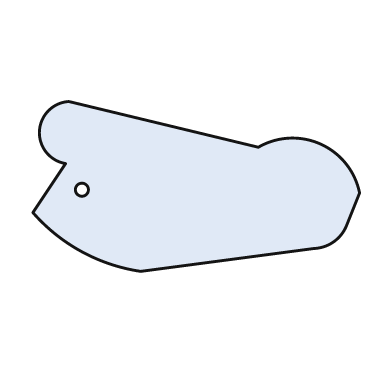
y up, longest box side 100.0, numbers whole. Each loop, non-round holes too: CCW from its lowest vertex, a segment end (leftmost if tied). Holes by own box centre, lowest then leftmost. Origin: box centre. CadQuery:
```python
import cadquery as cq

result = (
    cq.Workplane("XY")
    .moveTo(-17.0, -26.0)
    .lineTo(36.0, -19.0)
    .threePointArc((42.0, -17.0), (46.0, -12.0))
    .lineTo(50.0, -2.0)
    .threePointArc((38.0, 13.0), (19.0, 12.0))
    .lineTo(-39.0, 26.0)
    .threePointArc((-48.0, 17.0), (-40.0, 7.0))
    .lineTo(-50.0, -8.0)
    .threePointArc((-35.0, -20.0), (-17.0, -26.0))
    .close()
    .moveTo(-35.0, -1.0)
    .circle(2.0)
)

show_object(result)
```